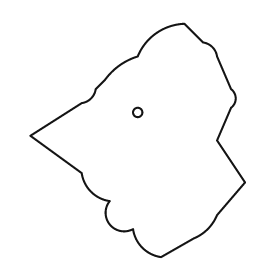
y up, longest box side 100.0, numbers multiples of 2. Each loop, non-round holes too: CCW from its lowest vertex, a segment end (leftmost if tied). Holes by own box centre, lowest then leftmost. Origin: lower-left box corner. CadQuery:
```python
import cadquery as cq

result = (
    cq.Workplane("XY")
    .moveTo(56.0, 0.0)
    .lineTo(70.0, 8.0)
    .threePointArc((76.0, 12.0), (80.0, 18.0))
    .lineTo(92.0, 32.0)
    .lineTo(80.0, 50.0)
    .lineTo(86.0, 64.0)
    .threePointArc((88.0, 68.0), (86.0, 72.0))
    .lineTo(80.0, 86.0)
    .threePointArc((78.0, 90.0), (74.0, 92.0))
    .lineTo(66.0, 100.0)
    .threePointArc((54.0, 96.0), (46.0, 86.0))
    .threePointArc((38.0, 82.0), (32.0, 76.0))
    .lineTo(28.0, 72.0)
    .threePointArc((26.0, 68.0), (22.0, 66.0))
    .lineTo(0.0, 52.0)
    .lineTo(22.0, 36.0)
    .threePointArc((26.0, 28.0), (34.0, 24.0))
    .threePointArc((34.0, 14.0), (44.0, 12.0))
    .threePointArc((48.0, 4.0), (56.0, 0.0))
    .close()
    .moveTo(46.0, 62.0)
    .circle(2.0)
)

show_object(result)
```